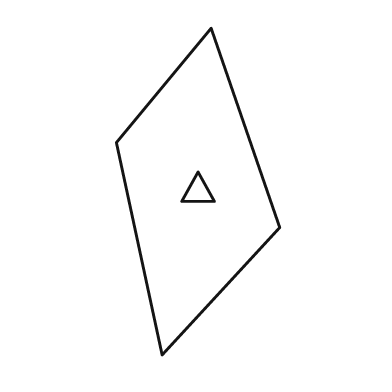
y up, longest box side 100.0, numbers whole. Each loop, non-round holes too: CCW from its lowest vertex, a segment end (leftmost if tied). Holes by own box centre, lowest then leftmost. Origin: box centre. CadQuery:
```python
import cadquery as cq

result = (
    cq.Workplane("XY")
    .moveTo(-11.0, -50.0)
    .lineTo(25.0, -11.0)
    .lineTo(4.0, 50.0)
    .lineTo(-25.0, 15.0)
    .close()
    .moveTo(-5.0, -3.0)
    .lineTo(5.0, -3.0)
    .lineTo(0.0, 6.0)
    .close()
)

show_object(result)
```